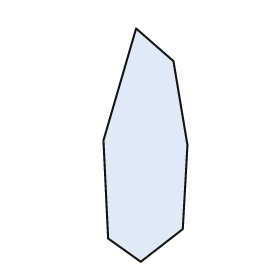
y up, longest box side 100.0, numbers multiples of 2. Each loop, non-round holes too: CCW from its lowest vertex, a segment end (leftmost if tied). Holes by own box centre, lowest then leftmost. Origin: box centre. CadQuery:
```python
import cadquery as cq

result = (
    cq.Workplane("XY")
    .moveTo(-2.0, -50.0)
    .lineTo(16.0, -36.0)
    .lineTo(18.0, 0.0)
    .lineTo(12.0, 36.0)
    .lineTo(-4.0, 50.0)
    .lineTo(-18.0, 2.0)
    .lineTo(-16.0, -40.0)
    .close()
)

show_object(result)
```